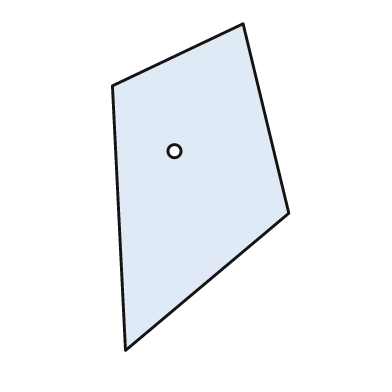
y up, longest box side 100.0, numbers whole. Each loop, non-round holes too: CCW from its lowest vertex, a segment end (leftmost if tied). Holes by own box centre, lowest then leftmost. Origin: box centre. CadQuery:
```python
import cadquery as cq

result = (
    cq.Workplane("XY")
    .moveTo(-23.0, -50.0)
    .lineTo(27.0, -8.0)
    .lineTo(13.0, 50.0)
    .lineTo(-27.0, 31.0)
    .close()
    .moveTo(-8.0, 11.0)
    .circle(2.0)
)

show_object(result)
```